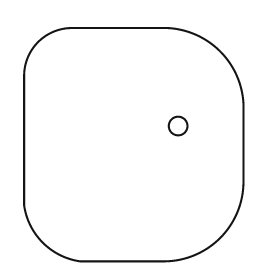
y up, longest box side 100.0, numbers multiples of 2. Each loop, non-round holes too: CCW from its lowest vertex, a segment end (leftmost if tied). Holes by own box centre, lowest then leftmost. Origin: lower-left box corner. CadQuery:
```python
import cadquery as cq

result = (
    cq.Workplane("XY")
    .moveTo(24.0, 0.0)
    .lineTo(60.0, 0.0)
    .threePointArc((84.0, 10.0), (94.0, 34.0))
    .lineTo(94.0, 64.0)
    .threePointArc((84.0, 90.0), (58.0, 100.0))
    .lineTo(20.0, 100.0)
    .threePointArc((6.0, 94.0), (0.0, 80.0))
    .lineTo(0.0, 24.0)
    .threePointArc((8.0, 8.0), (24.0, 0.0))
    .close()
    .moveTo(66.0, 58.0)
    .circle(4.0)
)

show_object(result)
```